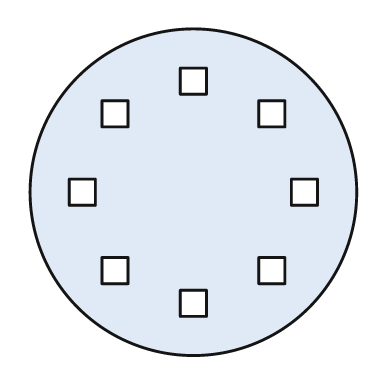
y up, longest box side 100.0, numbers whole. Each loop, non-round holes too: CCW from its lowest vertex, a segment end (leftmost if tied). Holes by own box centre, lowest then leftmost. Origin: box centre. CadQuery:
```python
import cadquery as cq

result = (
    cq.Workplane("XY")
    .moveTo(0.0, 0.0)
    .circle(50.0)
    .moveTo(-4.0, -38.0)
    .lineTo(4.0, -38.0)
    .lineTo(4.0, -30.0)
    .lineTo(-4.0, -30.0)
    .close()
    .moveTo(-28.0, -28.0)
    .lineTo(-20.0, -28.0)
    .lineTo(-20.0, -20.0)
    .lineTo(-28.0, -20.0)
    .close()
    .moveTo(20.0, -28.0)
    .lineTo(28.0, -28.0)
    .lineTo(28.0, -20.0)
    .lineTo(20.0, -20.0)
    .close()
    .moveTo(-38.0, -4.0)
    .lineTo(-30.0, -4.0)
    .lineTo(-30.0, 4.0)
    .lineTo(-38.0, 4.0)
    .close()
    .moveTo(30.0, -4.0)
    .lineTo(38.0, -4.0)
    .lineTo(38.0, 4.0)
    .lineTo(30.0, 4.0)
    .close()
    .moveTo(-28.0, 20.0)
    .lineTo(-20.0, 20.0)
    .lineTo(-20.0, 28.0)
    .lineTo(-28.0, 28.0)
    .close()
    .moveTo(20.0, 20.0)
    .lineTo(28.0, 20.0)
    .lineTo(28.0, 28.0)
    .lineTo(20.0, 28.0)
    .close()
    .moveTo(-4.0, 30.0)
    .lineTo(4.0, 30.0)
    .lineTo(4.0, 38.0)
    .lineTo(-4.0, 38.0)
    .close()
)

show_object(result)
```